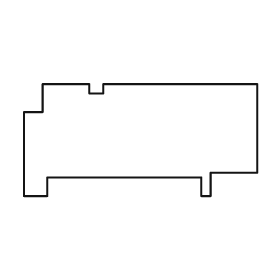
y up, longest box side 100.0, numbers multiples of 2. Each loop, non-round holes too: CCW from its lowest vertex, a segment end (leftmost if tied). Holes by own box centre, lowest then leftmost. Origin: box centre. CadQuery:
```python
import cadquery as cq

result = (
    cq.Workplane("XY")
    .moveTo(-50.0, -24.0)
    .lineTo(-40.0, -24.0)
    .lineTo(-40.0, -16.0)
    .lineTo(26.0, -16.0)
    .lineTo(26.0, -24.0)
    .lineTo(30.0, -24.0)
    .lineTo(30.0, -14.0)
    .lineTo(50.0, -14.0)
    .lineTo(50.0, 24.0)
    .lineTo(-16.0, 24.0)
    .lineTo(-16.0, 20.0)
    .lineTo(-22.0, 20.0)
    .lineTo(-22.0, 24.0)
    .lineTo(-42.0, 24.0)
    .lineTo(-42.0, 12.0)
    .lineTo(-50.0, 12.0)
    .close()
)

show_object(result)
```